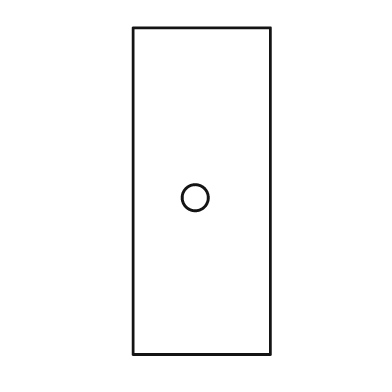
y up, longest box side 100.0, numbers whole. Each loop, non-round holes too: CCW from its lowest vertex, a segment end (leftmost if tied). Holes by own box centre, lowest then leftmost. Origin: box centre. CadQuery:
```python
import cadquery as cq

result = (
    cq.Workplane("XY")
    .moveTo(-21.0, -50.0)
    .lineTo(21.0, -50.0)
    .lineTo(21.0, 50.0)
    .lineTo(-21.0, 50.0)
    .close()
    .moveTo(-2.0, -2.0)
    .circle(4.0)
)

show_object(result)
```